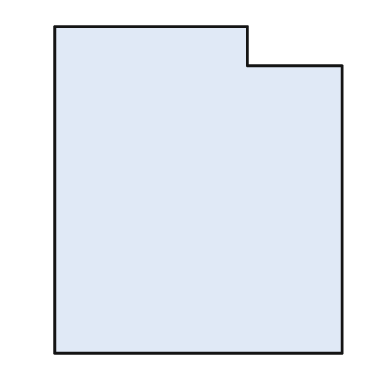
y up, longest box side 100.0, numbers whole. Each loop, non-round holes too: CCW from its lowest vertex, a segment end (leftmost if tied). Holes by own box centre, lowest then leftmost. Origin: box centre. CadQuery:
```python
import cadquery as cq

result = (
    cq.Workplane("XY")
    .moveTo(-44.0, -50.0)
    .lineTo(44.0, -50.0)
    .lineTo(44.0, 38.0)
    .lineTo(15.0, 38.0)
    .lineTo(15.0, 50.0)
    .lineTo(-44.0, 50.0)
    .close()
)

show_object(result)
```